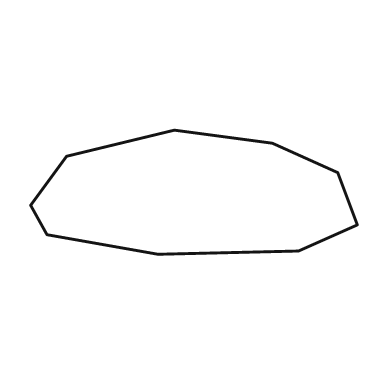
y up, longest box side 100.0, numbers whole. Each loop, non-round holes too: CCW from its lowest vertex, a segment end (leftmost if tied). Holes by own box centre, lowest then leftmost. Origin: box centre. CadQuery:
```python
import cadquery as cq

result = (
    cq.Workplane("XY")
    .moveTo(-11.0, -19.0)
    .lineTo(32.0, -18.0)
    .lineTo(50.0, -10.0)
    .lineTo(44.0, 6.0)
    .lineTo(24.0, 15.0)
    .lineTo(-6.0, 19.0)
    .lineTo(-39.0, 11.0)
    .lineTo(-50.0, -4.0)
    .lineTo(-45.0, -13.0)
    .close()
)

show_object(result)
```